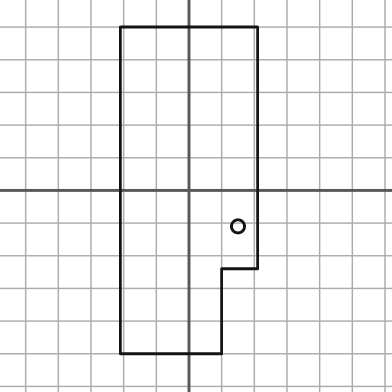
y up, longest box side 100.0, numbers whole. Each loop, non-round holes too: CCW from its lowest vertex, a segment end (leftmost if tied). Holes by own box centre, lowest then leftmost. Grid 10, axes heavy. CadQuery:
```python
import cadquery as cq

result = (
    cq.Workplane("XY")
    .moveTo(-21.0, -50.0)
    .lineTo(10.0, -50.0)
    .lineTo(10.0, -24.0)
    .lineTo(21.0, -24.0)
    .lineTo(21.0, 50.0)
    .lineTo(-21.0, 50.0)
    .close()
    .moveTo(15.0, -11.0)
    .circle(2.0)
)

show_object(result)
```